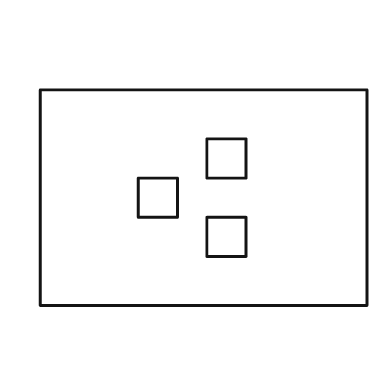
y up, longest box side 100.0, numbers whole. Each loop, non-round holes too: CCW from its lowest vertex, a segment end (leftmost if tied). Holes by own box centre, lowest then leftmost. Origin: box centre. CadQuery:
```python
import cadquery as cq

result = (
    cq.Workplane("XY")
    .moveTo(-50.0, -33.0)
    .lineTo(50.0, -33.0)
    .lineTo(50.0, 33.0)
    .lineTo(-50.0, 33.0)
    .close()
    .moveTo(1.0, -18.0)
    .lineTo(13.0, -18.0)
    .lineTo(13.0, -6.0)
    .lineTo(1.0, -6.0)
    .close()
    .moveTo(-20.0, -6.0)
    .lineTo(-8.0, -6.0)
    .lineTo(-8.0, 6.0)
    .lineTo(-20.0, 6.0)
    .close()
    .moveTo(1.0, 6.0)
    .lineTo(13.0, 6.0)
    .lineTo(13.0, 18.0)
    .lineTo(1.0, 18.0)
    .close()
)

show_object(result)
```